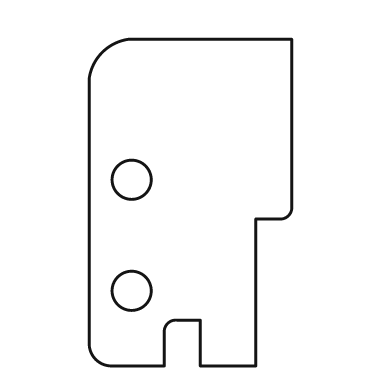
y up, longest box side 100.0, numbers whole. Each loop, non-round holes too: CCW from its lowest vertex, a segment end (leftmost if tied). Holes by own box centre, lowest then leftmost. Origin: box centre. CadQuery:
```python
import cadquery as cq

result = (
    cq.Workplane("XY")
    .moveTo(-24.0, -50.0)
    .lineTo(-8.0, -50.0)
    .lineTo(-8.0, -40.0)
    .threePointArc((-7.0, -37.0), (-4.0, -36.0))
    .lineTo(3.0, -36.0)
    .lineTo(3.0, -50.0)
    .lineTo(20.0, -50.0)
    .lineTo(20.0, -5.0)
    .lineTo(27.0, -5.0)
    .threePointArc((30.0, -4.0), (31.0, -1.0))
    .lineTo(31.0, 50.0)
    .lineTo(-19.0, 50.0)
    .threePointArc((-27.0, 46.0), (-31.0, 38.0))
    .lineTo(-31.0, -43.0)
    .threePointArc((-29.0, -48.0), (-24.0, -50.0))
    .close()
    .moveTo(-18.0, -27.0)
    .circle(6.0)
    .moveTo(-18.0, 7.0)
    .circle(6.0)
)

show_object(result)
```